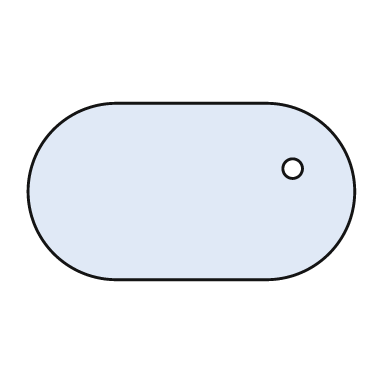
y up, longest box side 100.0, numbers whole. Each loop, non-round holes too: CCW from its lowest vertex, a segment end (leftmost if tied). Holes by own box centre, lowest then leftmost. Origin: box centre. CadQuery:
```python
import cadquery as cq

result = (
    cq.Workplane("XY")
    .moveTo(-23.0, -27.0)
    .lineTo(23.0, -27.0)
    .threePointArc((50.0, 0.0), (23.0, 27.0))
    .lineTo(-23.0, 27.0)
    .threePointArc((-50.0, 0.0), (-23.0, -27.0))
    .close()
    .moveTo(31.0, 7.0)
    .circle(3.0)
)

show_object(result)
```